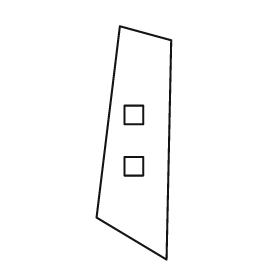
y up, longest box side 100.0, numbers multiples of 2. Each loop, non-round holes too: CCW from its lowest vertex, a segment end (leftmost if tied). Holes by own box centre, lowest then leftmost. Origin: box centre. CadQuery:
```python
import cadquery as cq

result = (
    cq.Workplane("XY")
    .moveTo(14.0, -50.0)
    .lineTo(16.0, 44.0)
    .lineTo(-6.0, 50.0)
    .lineTo(-16.0, -32.0)
    .close()
    .moveTo(-4.0, -14.0)
    .lineTo(4.0, -14.0)
    .lineTo(4.0, -6.0)
    .lineTo(-4.0, -6.0)
    .close()
    .moveTo(-4.0, 8.0)
    .lineTo(4.0, 8.0)
    .lineTo(4.0, 16.0)
    .lineTo(-4.0, 16.0)
    .close()
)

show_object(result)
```